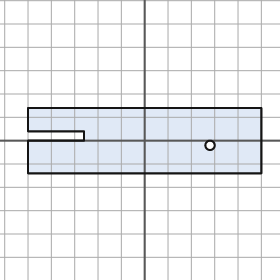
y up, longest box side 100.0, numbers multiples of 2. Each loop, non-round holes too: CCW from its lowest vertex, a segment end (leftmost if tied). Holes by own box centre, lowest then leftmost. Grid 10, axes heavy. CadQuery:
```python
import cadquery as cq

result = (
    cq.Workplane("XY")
    .moveTo(-50.0, -14.0)
    .lineTo(50.0, -14.0)
    .lineTo(50.0, 14.0)
    .lineTo(-50.0, 14.0)
    .lineTo(-50.0, 4.0)
    .lineTo(-26.0, 4.0)
    .lineTo(-26.0, 0.0)
    .lineTo(-50.0, 0.0)
    .close()
    .moveTo(28.0, -2.0)
    .circle(2.0)
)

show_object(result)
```